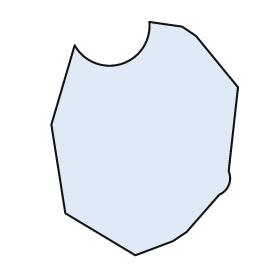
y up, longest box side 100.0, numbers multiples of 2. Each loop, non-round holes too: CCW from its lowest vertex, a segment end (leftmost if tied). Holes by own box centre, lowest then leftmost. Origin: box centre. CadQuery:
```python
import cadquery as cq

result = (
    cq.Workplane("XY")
    .moveTo(-4.0, -50.0)
    .lineTo(12.0, -44.0)
    .lineTo(18.0, -40.0)
    .lineTo(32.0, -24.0)
    .threePointArc((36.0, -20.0), (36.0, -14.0))
    .lineTo(40.0, 22.0)
    .lineTo(22.0, 44.0)
    .lineTo(16.0, 48.0)
    .lineTo(2.0, 50.0)
    .threePointArc((-10.0, 32.0), (-30.0, 40.0))
    .lineTo(-40.0, 6.0)
    .lineTo(-34.0, -32.0)
    .close()
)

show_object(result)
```